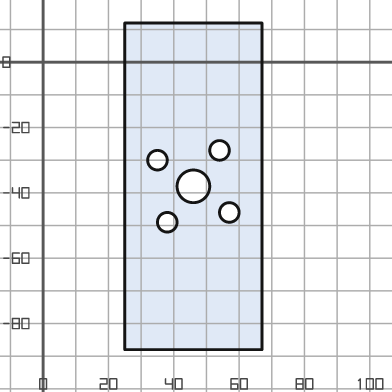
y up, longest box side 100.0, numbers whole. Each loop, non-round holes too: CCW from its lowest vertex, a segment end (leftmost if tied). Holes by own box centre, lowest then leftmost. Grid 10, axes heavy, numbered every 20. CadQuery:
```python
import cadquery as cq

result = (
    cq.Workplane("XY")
    .moveTo(25.0, -88.0)
    .lineTo(67.0, -88.0)
    .lineTo(67.0, 12.0)
    .lineTo(25.0, 12.0)
    .close()
    .moveTo(38.0, -49.0)
    .circle(3.0)
    .moveTo(57.0, -46.0)
    .circle(3.0)
    .moveTo(46.0, -38.0)
    .circle(5.0)
    .moveTo(35.0, -30.0)
    .circle(3.0)
    .moveTo(54.0, -27.0)
    .circle(3.0)
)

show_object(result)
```